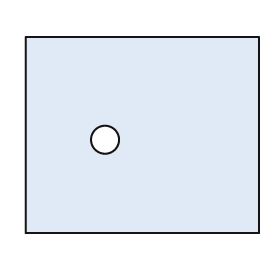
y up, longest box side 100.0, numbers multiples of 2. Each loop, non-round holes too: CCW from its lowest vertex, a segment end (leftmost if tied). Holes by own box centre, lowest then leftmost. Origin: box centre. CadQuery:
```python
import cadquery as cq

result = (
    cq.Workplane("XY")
    .moveTo(-50.0, -42.0)
    .lineTo(50.0, -42.0)
    .lineTo(50.0, 42.0)
    .lineTo(-50.0, 42.0)
    .close()
    .moveTo(-16.0, -2.0)
    .circle(6.0)
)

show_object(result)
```